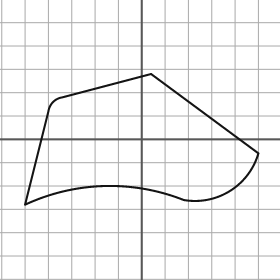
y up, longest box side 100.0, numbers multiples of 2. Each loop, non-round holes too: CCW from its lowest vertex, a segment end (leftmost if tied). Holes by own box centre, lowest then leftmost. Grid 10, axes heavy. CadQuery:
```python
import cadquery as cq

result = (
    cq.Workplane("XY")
    .moveTo(-50.0, -28.0)
    .threePointArc((-16.0, -20.0), (18.0, -26.0))
    .threePointArc((38.0, -22.0), (50.0, -6.0))
    .lineTo(4.0, 28.0)
    .lineTo(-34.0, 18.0)
    .threePointArc((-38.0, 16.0), (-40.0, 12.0))
    .close()
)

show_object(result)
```